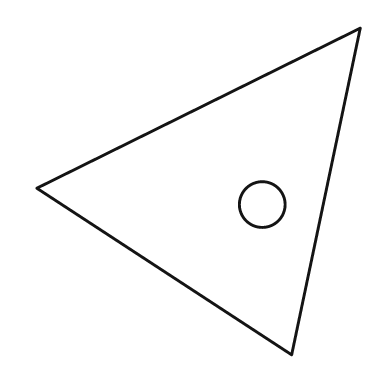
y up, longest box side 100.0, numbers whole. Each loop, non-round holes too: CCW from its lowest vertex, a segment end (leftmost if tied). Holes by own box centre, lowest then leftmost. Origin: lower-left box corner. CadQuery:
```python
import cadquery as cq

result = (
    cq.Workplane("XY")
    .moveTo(78.0, 0.0)
    .lineTo(99.0, 100.0)
    .lineTo(0.0, 51.0)
    .close()
    .moveTo(69.0, 46.0)
    .circle(7.0)
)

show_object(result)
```